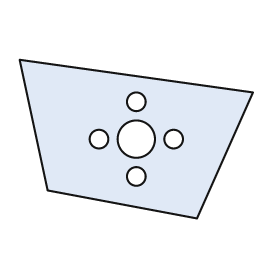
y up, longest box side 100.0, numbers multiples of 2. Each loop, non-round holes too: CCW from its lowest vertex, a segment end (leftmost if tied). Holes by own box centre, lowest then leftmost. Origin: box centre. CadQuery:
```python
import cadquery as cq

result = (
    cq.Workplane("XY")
    .moveTo(26.0, -34.0)
    .lineTo(50.0, 20.0)
    .lineTo(-50.0, 34.0)
    .lineTo(-38.0, -22.0)
    .close()
    .moveTo(0.0, -16.0)
    .circle(4.0)
    .moveTo(-16.0, 0.0)
    .circle(4.0)
    .moveTo(0.0, 0.0)
    .circle(8.0)
    .moveTo(16.0, 0.0)
    .circle(4.0)
    .moveTo(0.0, 16.0)
    .circle(4.0)
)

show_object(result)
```